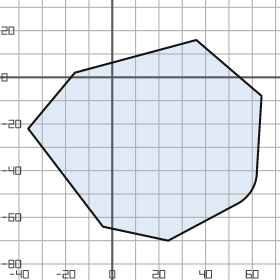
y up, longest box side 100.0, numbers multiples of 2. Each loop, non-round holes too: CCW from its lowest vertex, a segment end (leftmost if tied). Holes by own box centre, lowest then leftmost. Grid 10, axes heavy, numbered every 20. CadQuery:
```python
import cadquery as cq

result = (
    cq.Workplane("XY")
    .moveTo(24.0, -70.0)
    .lineTo(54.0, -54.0)
    .threePointArc((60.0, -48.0), (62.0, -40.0))
    .lineTo(64.0, -8.0)
    .lineTo(36.0, 16.0)
    .lineTo(-16.0, 2.0)
    .lineTo(-36.0, -22.0)
    .lineTo(-4.0, -64.0)
    .close()
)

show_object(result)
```